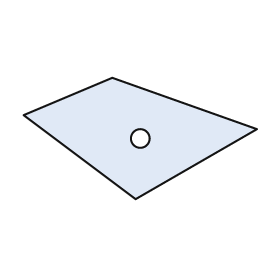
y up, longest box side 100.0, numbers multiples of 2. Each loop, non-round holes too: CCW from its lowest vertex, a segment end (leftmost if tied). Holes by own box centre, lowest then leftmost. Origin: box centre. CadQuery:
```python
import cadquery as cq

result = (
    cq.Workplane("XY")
    .moveTo(-2.0, -26.0)
    .lineTo(50.0, 4.0)
    .lineTo(-12.0, 26.0)
    .lineTo(-50.0, 10.0)
    .close()
    .moveTo(0.0, 0.0)
    .circle(4.0)
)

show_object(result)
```